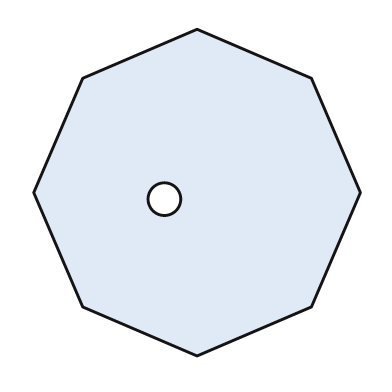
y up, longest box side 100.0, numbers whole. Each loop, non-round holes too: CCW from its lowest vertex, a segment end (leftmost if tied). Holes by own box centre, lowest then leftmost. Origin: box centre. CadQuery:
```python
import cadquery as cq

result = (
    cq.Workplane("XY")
    .moveTo(0.0, -50.0)
    .lineTo(35.0, -35.0)
    .lineTo(50.0, 0.0)
    .lineTo(35.0, 35.0)
    .lineTo(0.0, 50.0)
    .lineTo(-35.0, 35.0)
    .lineTo(-50.0, 0.0)
    .lineTo(-35.0, -35.0)
    .close()
    .moveTo(-10.0, -2.0)
    .circle(5.0)
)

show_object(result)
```